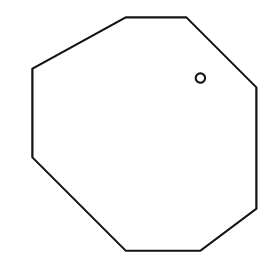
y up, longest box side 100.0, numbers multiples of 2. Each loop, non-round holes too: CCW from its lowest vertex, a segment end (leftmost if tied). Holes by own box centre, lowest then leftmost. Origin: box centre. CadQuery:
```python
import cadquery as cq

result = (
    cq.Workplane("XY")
    .moveTo(-8.0, -50.0)
    .lineTo(24.0, -50.0)
    .lineTo(48.0, -32.0)
    .lineTo(48.0, 20.0)
    .lineTo(18.0, 50.0)
    .lineTo(-8.0, 50.0)
    .lineTo(-48.0, 28.0)
    .lineTo(-48.0, -10.0)
    .close()
    .moveTo(24.0, 24.0)
    .circle(2.0)
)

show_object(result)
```